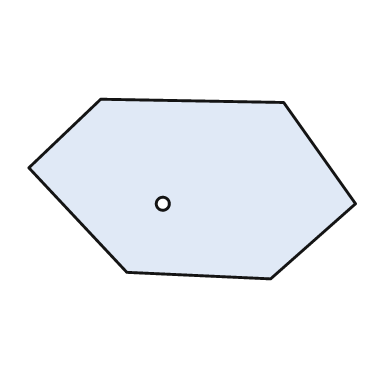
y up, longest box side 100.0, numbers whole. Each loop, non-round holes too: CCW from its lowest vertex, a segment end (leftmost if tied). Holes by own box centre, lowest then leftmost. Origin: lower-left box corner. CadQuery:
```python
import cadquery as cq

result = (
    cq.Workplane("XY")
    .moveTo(74.0, 0.0)
    .lineTo(100.0, 23.0)
    .lineTo(78.0, 54.0)
    .lineTo(22.0, 55.0)
    .lineTo(0.0, 34.0)
    .lineTo(30.0, 2.0)
    .close()
    .moveTo(41.0, 23.0)
    .circle(2.0)
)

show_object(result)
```